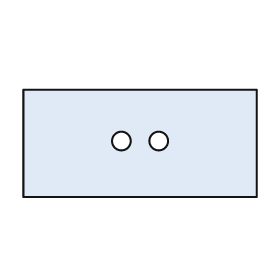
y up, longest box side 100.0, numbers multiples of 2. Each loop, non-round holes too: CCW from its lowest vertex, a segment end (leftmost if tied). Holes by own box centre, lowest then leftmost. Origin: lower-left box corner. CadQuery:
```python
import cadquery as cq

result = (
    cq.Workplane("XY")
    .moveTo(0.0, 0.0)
    .lineTo(100.0, 0.0)
    .lineTo(100.0, 46.0)
    .lineTo(0.0, 46.0)
    .close()
    .moveTo(42.0, 24.0)
    .circle(4.0)
    .moveTo(58.0, 24.0)
    .circle(4.0)
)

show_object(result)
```